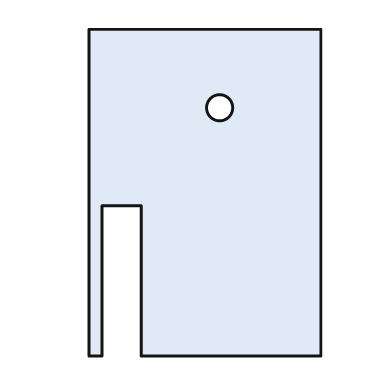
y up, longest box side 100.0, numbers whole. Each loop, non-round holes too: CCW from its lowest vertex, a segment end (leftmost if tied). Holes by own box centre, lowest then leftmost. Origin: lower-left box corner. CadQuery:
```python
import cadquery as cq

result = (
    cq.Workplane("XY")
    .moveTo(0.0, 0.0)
    .lineTo(4.0, 0.0)
    .lineTo(4.0, 46.0)
    .lineTo(16.0, 46.0)
    .lineTo(16.0, 0.0)
    .lineTo(71.0, 0.0)
    .lineTo(71.0, 100.0)
    .lineTo(0.0, 100.0)
    .close()
    .moveTo(40.0, 76.0)
    .circle(4.0)
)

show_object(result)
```